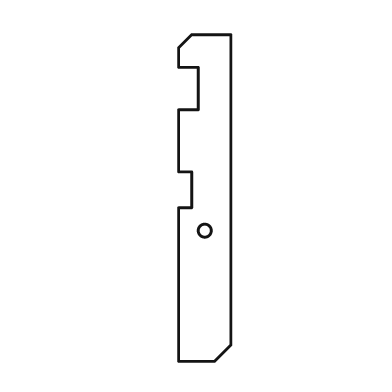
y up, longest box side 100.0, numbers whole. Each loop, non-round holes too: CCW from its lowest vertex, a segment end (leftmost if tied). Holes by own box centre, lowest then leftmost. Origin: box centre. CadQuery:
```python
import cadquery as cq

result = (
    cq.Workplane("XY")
    .moveTo(-8.0, -50.0)
    .lineTo(3.0, -50.0)
    .lineTo(8.0, -45.0)
    .lineTo(8.0, 50.0)
    .lineTo(-4.0, 50.0)
    .lineTo(-8.0, 46.0)
    .lineTo(-8.0, 40.0)
    .lineTo(-2.0, 40.0)
    .lineTo(-2.0, 27.0)
    .lineTo(-8.0, 27.0)
    .lineTo(-8.0, 8.0)
    .lineTo(-4.0, 8.0)
    .lineTo(-4.0, -3.0)
    .lineTo(-8.0, -3.0)
    .close()
    .moveTo(0.0, -10.0)
    .circle(2.0)
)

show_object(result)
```